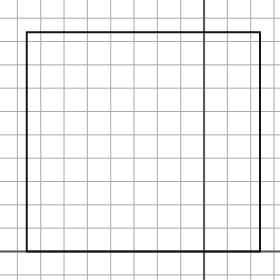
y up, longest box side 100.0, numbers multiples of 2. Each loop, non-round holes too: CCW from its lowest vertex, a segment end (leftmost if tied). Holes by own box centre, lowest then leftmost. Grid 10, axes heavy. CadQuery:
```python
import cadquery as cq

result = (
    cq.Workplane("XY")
    .moveTo(-76.0, 0.0)
    .lineTo(24.0, 0.0)
    .lineTo(24.0, 94.0)
    .lineTo(-76.0, 94.0)
    .close()
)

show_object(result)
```